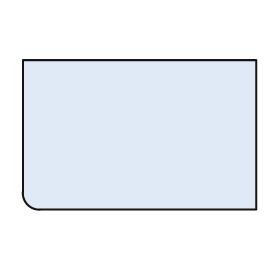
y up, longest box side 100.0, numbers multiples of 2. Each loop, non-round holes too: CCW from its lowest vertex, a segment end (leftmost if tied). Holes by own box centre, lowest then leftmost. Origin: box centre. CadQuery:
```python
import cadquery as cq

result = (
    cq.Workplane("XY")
    .moveTo(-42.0, -32.0)
    .lineTo(50.0, -32.0)
    .lineTo(50.0, 32.0)
    .lineTo(-50.0, 32.0)
    .lineTo(-50.0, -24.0)
    .threePointArc((-48.0, -30.0), (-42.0, -32.0))
    .close()
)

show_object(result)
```